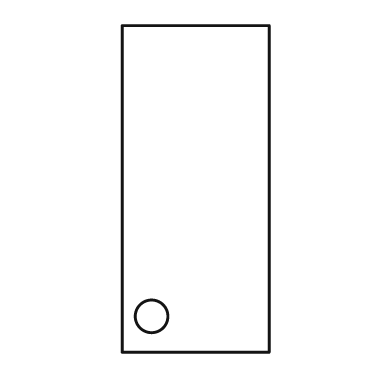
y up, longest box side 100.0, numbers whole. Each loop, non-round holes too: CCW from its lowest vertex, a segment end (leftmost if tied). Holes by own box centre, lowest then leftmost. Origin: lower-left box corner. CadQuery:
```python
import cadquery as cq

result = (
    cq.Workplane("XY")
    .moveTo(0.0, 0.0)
    .lineTo(45.0, 0.0)
    .lineTo(45.0, 100.0)
    .lineTo(0.0, 100.0)
    .close()
    .moveTo(9.0, 11.0)
    .circle(5.0)
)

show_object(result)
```